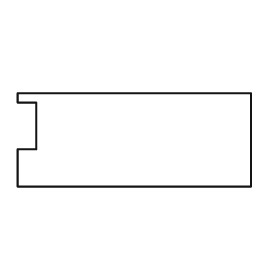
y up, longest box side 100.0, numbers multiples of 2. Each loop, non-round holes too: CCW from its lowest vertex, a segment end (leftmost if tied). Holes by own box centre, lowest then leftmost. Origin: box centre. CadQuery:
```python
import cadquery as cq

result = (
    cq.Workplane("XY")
    .moveTo(-50.0, -20.0)
    .lineTo(50.0, -20.0)
    .lineTo(50.0, 20.0)
    .lineTo(-50.0, 20.0)
    .lineTo(-50.0, 16.0)
    .lineTo(-42.0, 16.0)
    .lineTo(-42.0, -4.0)
    .lineTo(-50.0, -4.0)
    .close()
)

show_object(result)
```